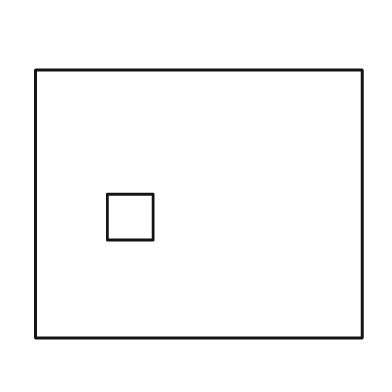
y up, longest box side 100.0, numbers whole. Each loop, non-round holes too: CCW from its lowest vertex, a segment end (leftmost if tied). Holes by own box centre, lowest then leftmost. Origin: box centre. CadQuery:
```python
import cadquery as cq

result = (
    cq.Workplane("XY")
    .moveTo(-50.0, -41.0)
    .lineTo(50.0, -41.0)
    .lineTo(50.0, 41.0)
    .lineTo(-50.0, 41.0)
    .close()
    .moveTo(-28.0, -11.0)
    .lineTo(-14.0, -11.0)
    .lineTo(-14.0, 3.0)
    .lineTo(-28.0, 3.0)
    .close()
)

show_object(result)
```